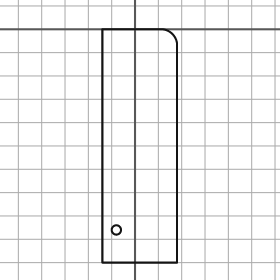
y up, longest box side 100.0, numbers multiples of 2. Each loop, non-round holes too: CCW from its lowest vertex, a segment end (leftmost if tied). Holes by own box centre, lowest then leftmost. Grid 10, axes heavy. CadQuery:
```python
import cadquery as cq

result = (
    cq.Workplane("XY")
    .moveTo(-14.0, -100.0)
    .lineTo(18.0, -100.0)
    .lineTo(18.0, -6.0)
    .threePointArc((16.0, -2.0), (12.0, 0.0))
    .lineTo(-14.0, 0.0)
    .close()
    .moveTo(-8.0, -86.0)
    .circle(2.0)
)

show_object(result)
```